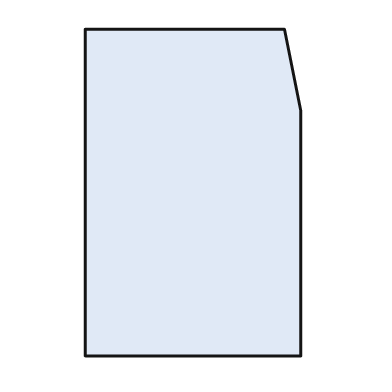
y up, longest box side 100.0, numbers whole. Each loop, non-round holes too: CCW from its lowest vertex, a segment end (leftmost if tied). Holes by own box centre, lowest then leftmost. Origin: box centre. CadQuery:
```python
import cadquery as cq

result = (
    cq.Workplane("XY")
    .moveTo(-33.0, -50.0)
    .lineTo(33.0, -50.0)
    .lineTo(33.0, 25.0)
    .lineTo(28.0, 50.0)
    .lineTo(-33.0, 50.0)
    .close()
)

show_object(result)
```